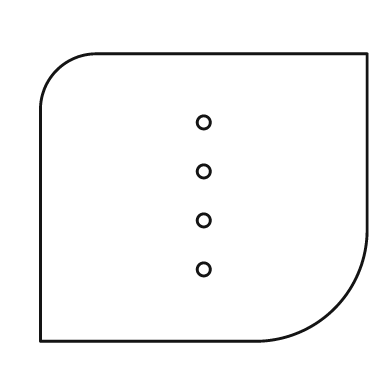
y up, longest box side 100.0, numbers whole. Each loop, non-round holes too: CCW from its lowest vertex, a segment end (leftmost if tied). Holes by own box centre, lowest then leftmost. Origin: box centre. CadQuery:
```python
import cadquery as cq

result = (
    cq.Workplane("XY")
    .moveTo(-50.0, -44.0)
    .lineTo(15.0, -44.0)
    .threePointArc((40.0, -34.0), (50.0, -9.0))
    .lineTo(50.0, 44.0)
    .lineTo(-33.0, 44.0)
    .threePointArc((-45.0, 39.0), (-50.0, 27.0))
    .close()
    .moveTo(0.0, -22.0)
    .circle(2.0)
    .moveTo(0.0, -7.0)
    .circle(2.0)
    .moveTo(0.0, 8.0)
    .circle(2.0)
    .moveTo(0.0, 23.0)
    .circle(2.0)
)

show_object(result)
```